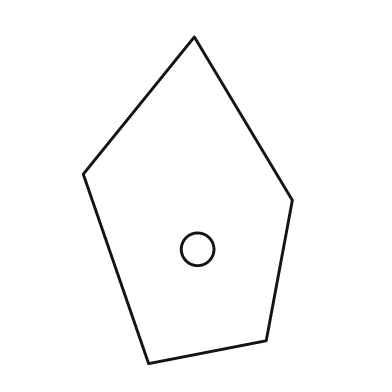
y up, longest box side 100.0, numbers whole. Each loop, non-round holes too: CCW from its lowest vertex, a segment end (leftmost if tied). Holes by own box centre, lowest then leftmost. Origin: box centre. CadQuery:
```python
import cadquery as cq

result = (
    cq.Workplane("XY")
    .moveTo(-12.0, -50.0)
    .lineTo(24.0, -43.0)
    .lineTo(32.0, 0.0)
    .lineTo(2.0, 50.0)
    .lineTo(-32.0, 8.0)
    .close()
    .moveTo(3.0, -15.0)
    .circle(5.0)
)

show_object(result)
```